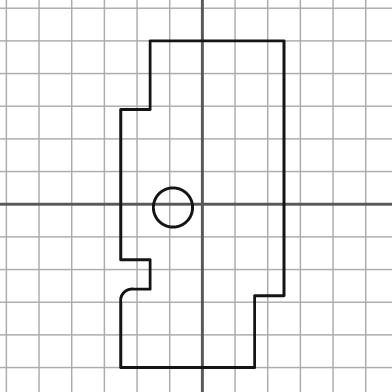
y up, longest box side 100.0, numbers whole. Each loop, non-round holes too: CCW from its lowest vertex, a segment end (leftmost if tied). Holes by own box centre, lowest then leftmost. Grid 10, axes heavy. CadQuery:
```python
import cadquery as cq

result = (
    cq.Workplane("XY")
    .moveTo(-25.0, -50.0)
    .lineTo(16.0, -50.0)
    .lineTo(16.0, -28.0)
    .lineTo(25.0, -28.0)
    .lineTo(25.0, 50.0)
    .lineTo(-16.0, 50.0)
    .lineTo(-16.0, 29.0)
    .lineTo(-25.0, 29.0)
    .lineTo(-25.0, -17.0)
    .lineTo(-16.0, -17.0)
    .lineTo(-16.0, -26.0)
    .lineTo(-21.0, -26.0)
    .threePointArc((-24.0, -27.0), (-25.0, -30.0))
    .close()
    .moveTo(-9.0, -1.0)
    .circle(6.0)
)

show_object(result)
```